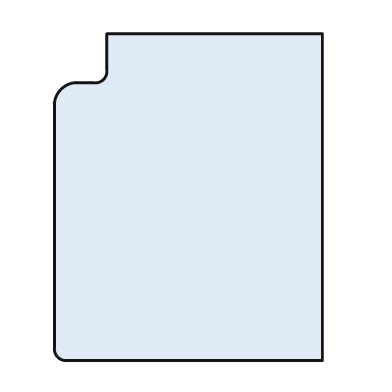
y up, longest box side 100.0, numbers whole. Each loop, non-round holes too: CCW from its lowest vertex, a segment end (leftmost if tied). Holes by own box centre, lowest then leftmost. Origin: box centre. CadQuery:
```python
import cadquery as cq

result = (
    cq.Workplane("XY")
    .moveTo(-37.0, -50.0)
    .lineTo(41.0, -50.0)
    .lineTo(41.0, 50.0)
    .lineTo(-25.0, 50.0)
    .lineTo(-25.0, 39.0)
    .threePointArc((-26.0, 36.0), (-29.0, 35.0))
    .lineTo(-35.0, 35.0)
    .threePointArc((-39.0, 33.0), (-41.0, 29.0))
    .lineTo(-41.0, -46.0)
    .threePointArc((-40.0, -49.0), (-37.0, -50.0))
    .close()
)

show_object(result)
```